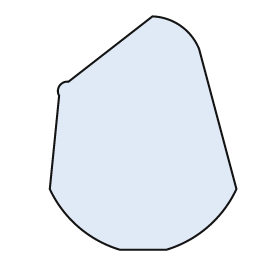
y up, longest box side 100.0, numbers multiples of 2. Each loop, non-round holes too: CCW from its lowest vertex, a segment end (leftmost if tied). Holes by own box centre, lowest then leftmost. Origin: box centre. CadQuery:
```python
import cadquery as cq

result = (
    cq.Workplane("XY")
    .moveTo(-10.0, -50.0)
    .lineTo(10.0, -50.0)
    .threePointArc((28.0, -40.0), (40.0, -24.0))
    .lineTo(24.0, 36.0)
    .threePointArc((16.0, 46.0), (4.0, 50.0))
    .lineTo(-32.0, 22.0)
    .threePointArc((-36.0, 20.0), (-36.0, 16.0))
    .lineTo(-40.0, -24.0)
    .threePointArc((-28.0, -40.0), (-10.0, -50.0))
    .close()
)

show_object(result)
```